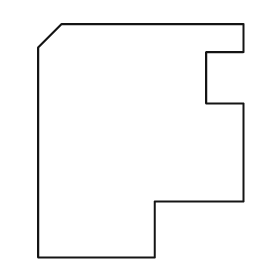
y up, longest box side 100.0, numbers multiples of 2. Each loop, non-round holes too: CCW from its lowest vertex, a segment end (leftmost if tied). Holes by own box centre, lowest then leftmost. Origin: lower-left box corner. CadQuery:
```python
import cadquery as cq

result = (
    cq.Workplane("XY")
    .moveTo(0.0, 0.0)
    .lineTo(50.0, 0.0)
    .lineTo(50.0, 24.0)
    .lineTo(88.0, 24.0)
    .lineTo(88.0, 66.0)
    .lineTo(72.0, 66.0)
    .lineTo(72.0, 88.0)
    .lineTo(88.0, 88.0)
    .lineTo(88.0, 100.0)
    .lineTo(10.0, 100.0)
    .lineTo(0.0, 90.0)
    .close()
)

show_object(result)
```